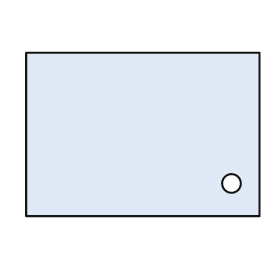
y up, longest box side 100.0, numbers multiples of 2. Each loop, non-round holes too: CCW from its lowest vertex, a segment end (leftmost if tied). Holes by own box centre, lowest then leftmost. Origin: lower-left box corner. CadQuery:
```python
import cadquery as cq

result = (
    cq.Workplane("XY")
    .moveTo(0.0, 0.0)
    .lineTo(100.0, 0.0)
    .lineTo(100.0, 70.0)
    .lineTo(0.0, 70.0)
    .close()
    .moveTo(88.0, 14.0)
    .circle(4.0)
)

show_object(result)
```